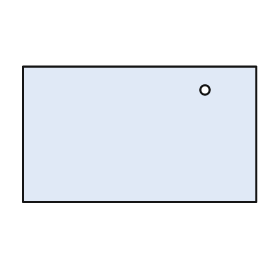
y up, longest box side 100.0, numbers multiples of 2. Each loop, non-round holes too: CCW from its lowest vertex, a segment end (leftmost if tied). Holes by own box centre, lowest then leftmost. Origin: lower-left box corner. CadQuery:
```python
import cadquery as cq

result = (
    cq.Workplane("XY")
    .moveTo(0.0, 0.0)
    .lineTo(100.0, 0.0)
    .lineTo(100.0, 58.0)
    .lineTo(0.0, 58.0)
    .close()
    .moveTo(78.0, 48.0)
    .circle(2.0)
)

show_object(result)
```